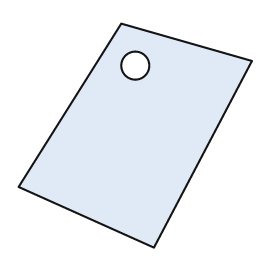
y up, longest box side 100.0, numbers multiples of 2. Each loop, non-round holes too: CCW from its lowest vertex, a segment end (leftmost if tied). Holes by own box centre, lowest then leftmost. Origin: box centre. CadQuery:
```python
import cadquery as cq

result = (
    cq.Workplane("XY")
    .moveTo(8.0, -48.0)
    .lineTo(50.0, 32.0)
    .lineTo(-6.0, 48.0)
    .lineTo(-50.0, -22.0)
    .close()
    .moveTo(0.0, 30.0)
    .circle(6.0)
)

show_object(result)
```